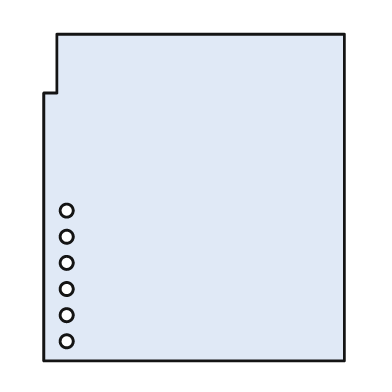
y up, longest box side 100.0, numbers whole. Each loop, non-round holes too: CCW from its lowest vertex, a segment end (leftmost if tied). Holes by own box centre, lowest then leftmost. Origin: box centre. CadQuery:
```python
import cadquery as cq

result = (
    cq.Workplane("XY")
    .moveTo(-46.0, -50.0)
    .lineTo(46.0, -50.0)
    .lineTo(46.0, 50.0)
    .lineTo(-42.0, 50.0)
    .lineTo(-42.0, 32.0)
    .lineTo(-46.0, 32.0)
    .close()
    .moveTo(-39.0, -44.0)
    .circle(2.0)
    .moveTo(-39.0, -36.0)
    .circle(2.0)
    .moveTo(-39.0, -28.0)
    .circle(2.0)
    .moveTo(-39.0, -20.0)
    .circle(2.0)
    .moveTo(-39.0, -12.0)
    .circle(2.0)
    .moveTo(-39.0, -4.0)
    .circle(2.0)
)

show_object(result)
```